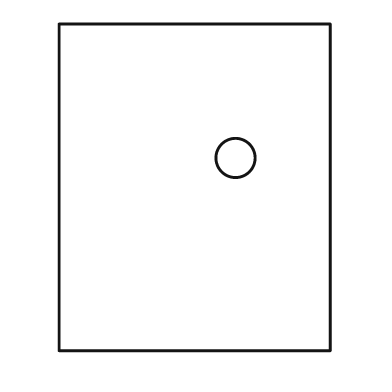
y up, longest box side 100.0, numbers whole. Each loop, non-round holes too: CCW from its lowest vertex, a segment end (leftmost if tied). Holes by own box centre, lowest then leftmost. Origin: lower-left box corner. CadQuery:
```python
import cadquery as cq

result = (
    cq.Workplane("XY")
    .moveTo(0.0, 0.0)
    .lineTo(83.0, 0.0)
    .lineTo(83.0, 100.0)
    .lineTo(0.0, 100.0)
    .close()
    .moveTo(54.0, 59.0)
    .circle(6.0)
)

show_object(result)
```